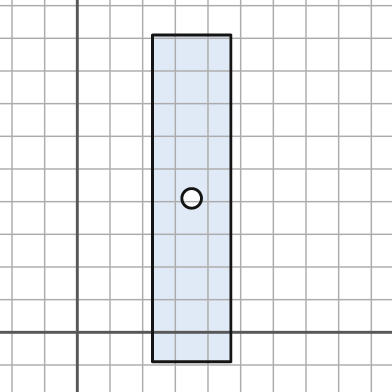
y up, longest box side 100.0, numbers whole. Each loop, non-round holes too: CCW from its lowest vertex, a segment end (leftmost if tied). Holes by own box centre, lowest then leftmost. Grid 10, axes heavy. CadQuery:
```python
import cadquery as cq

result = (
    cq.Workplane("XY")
    .moveTo(23.0, -9.0)
    .lineTo(47.0, -9.0)
    .lineTo(47.0, 91.0)
    .lineTo(23.0, 91.0)
    .close()
    .moveTo(35.0, 41.0)
    .circle(3.0)
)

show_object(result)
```